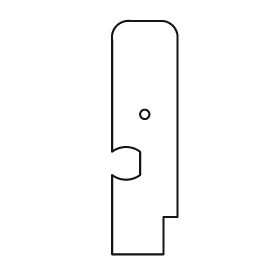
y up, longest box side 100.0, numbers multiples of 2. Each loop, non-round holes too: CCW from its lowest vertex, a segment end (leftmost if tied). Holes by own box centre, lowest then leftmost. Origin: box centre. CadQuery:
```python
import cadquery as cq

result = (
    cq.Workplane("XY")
    .moveTo(-14.0, -50.0)
    .lineTo(8.0, -50.0)
    .lineTo(8.0, -34.0)
    .lineTo(14.0, -34.0)
    .lineTo(14.0, 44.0)
    .threePointArc((12.0, 48.0), (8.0, 50.0))
    .lineTo(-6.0, 50.0)
    .threePointArc((-12.0, 48.0), (-14.0, 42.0))
    .lineTo(-14.0, -6.0)
    .threePointArc((-8.0, -4.0), (-2.0, -6.0))
    .lineTo(-2.0, -16.0)
    .threePointArc((-8.0, -18.0), (-14.0, -16.0))
    .close()
    .moveTo(0.0, 10.0)
    .circle(2.0)
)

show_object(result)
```